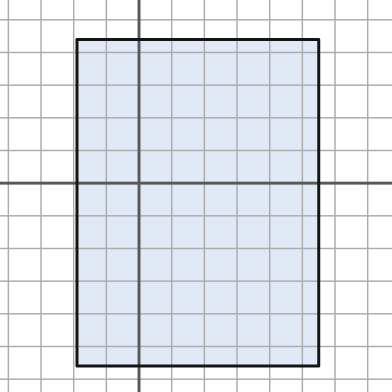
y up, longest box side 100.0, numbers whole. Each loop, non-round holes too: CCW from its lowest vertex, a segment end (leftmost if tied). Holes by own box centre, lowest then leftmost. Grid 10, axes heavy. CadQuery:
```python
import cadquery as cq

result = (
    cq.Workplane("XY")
    .moveTo(-19.0, -56.0)
    .lineTo(55.0, -56.0)
    .lineTo(55.0, 44.0)
    .lineTo(-19.0, 44.0)
    .close()
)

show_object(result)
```